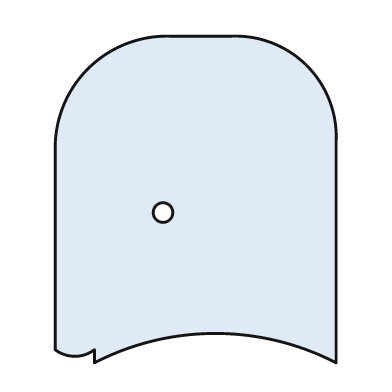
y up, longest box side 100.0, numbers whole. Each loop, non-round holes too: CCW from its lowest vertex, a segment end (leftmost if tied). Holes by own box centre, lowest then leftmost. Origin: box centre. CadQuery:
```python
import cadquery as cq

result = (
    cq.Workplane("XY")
    .moveTo(-31.0, -50.0)
    .threePointArc((6.0, -41.0), (43.0, -50.0))
    .lineTo(43.0, 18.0)
    .threePointArc((34.0, 41.0), (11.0, 50.0))
    .lineTo(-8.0, 50.0)
    .threePointArc((-33.0, 40.0), (-43.0, 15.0))
    .lineTo(-43.0, -46.0)
    .threePointArc((-37.0, -48.0), (-31.0, -46.0))
    .close()
    .moveTo(-10.0, -4.0)
    .circle(3.0)
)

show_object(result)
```